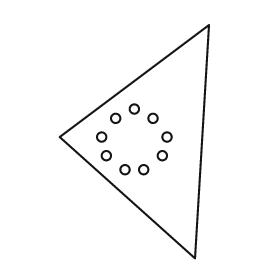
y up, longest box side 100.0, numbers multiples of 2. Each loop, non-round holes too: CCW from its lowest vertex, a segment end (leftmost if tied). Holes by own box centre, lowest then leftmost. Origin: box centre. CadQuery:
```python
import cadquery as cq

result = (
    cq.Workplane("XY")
    .moveTo(26.0, -50.0)
    .lineTo(32.0, 50.0)
    .lineTo(-32.0, 2.0)
    .close()
    .moveTo(-4.0, -12.0)
    .circle(2.0)
    .moveTo(4.0, -12.0)
    .circle(2.0)
    .moveTo(-12.0, -6.0)
    .circle(2.0)
    .moveTo(12.0, -6.0)
    .circle(2.0)
    .moveTo(-14.0, 2.0)
    .circle(2.0)
    .moveTo(14.0, 2.0)
    .circle(2.0)
    .moveTo(-8.0, 10.0)
    .circle(2.0)
    .moveTo(8.0, 10.0)
    .circle(2.0)
    .moveTo(0.0, 14.0)
    .circle(2.0)
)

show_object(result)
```